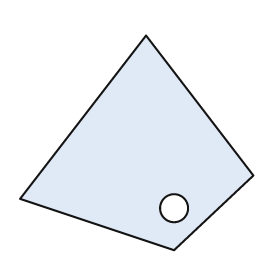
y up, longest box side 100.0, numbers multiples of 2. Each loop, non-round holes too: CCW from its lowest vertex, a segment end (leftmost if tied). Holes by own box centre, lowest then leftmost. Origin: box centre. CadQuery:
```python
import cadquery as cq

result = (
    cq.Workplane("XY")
    .moveTo(16.0, -46.0)
    .lineTo(50.0, -14.0)
    .lineTo(4.0, 46.0)
    .lineTo(-50.0, -24.0)
    .close()
    .moveTo(16.0, -28.0)
    .circle(6.0)
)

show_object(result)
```